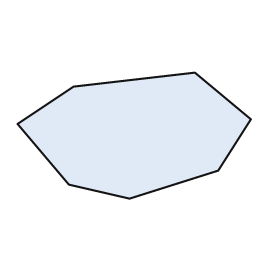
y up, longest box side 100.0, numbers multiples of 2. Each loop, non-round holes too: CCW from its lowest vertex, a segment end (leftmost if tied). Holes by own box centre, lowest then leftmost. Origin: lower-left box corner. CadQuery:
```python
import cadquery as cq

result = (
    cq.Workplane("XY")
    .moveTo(48.0, 0.0)
    .lineTo(86.0, 12.0)
    .lineTo(100.0, 34.0)
    .lineTo(76.0, 54.0)
    .lineTo(24.0, 48.0)
    .lineTo(0.0, 32.0)
    .lineTo(22.0, 6.0)
    .close()
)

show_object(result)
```